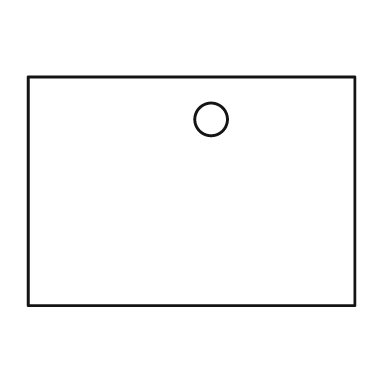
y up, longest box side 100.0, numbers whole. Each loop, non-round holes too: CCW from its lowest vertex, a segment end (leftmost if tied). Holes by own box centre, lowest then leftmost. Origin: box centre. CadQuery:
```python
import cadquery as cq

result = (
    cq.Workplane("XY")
    .moveTo(-50.0, -35.0)
    .lineTo(50.0, -35.0)
    .lineTo(50.0, 35.0)
    .lineTo(-50.0, 35.0)
    .close()
    .moveTo(6.0, 22.0)
    .circle(5.0)
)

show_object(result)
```